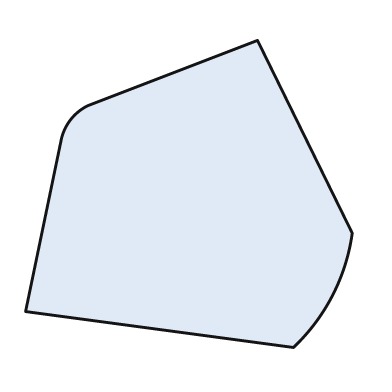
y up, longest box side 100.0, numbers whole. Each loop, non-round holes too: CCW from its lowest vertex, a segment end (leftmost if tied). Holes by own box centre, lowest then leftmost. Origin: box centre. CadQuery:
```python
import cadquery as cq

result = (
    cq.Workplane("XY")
    .moveTo(32.0, -47.0)
    .threePointArc((44.0, -31.0), (50.0, -12.0))
    .lineTo(21.0, 47.0)
    .lineTo(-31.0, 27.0)
    .threePointArc((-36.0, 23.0), (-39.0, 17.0))
    .lineTo(-50.0, -36.0)
    .close()
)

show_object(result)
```